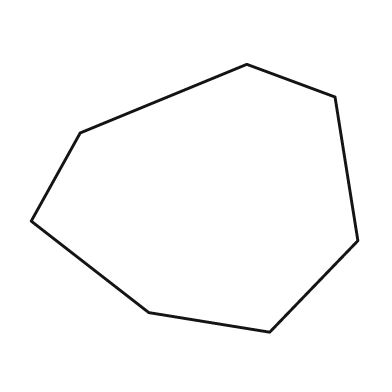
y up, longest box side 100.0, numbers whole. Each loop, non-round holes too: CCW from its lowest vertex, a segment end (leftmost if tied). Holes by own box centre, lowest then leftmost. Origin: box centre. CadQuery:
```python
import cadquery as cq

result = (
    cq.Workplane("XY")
    .moveTo(23.0, -41.0)
    .lineTo(50.0, -13.0)
    .lineTo(43.0, 31.0)
    .lineTo(16.0, 41.0)
    .lineTo(-35.0, 20.0)
    .lineTo(-50.0, -7.0)
    .lineTo(-14.0, -35.0)
    .close()
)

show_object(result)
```